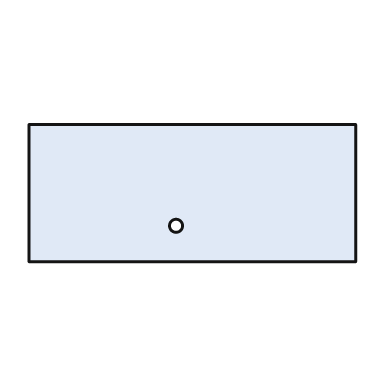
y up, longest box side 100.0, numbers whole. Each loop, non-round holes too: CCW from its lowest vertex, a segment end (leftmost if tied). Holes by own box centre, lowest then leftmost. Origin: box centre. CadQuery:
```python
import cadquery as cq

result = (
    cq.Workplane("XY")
    .moveTo(-50.0, -21.0)
    .lineTo(50.0, -21.0)
    .lineTo(50.0, 21.0)
    .lineTo(-50.0, 21.0)
    .close()
    .moveTo(-5.0, -10.0)
    .circle(2.0)
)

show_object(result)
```